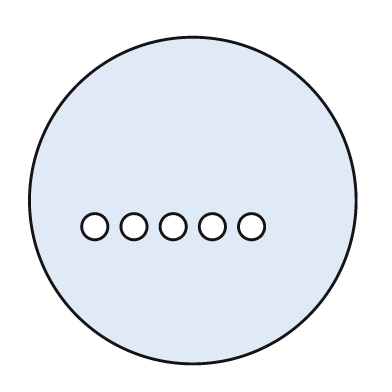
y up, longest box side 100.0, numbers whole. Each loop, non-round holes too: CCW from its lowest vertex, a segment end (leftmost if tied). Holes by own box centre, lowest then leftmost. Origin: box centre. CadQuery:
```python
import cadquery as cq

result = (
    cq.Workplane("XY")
    .moveTo(0.0, 0.0)
    .circle(50.0)
    .moveTo(-30.0, -8.0)
    .circle(4.0)
    .moveTo(-18.0, -8.0)
    .circle(4.0)
    .moveTo(-6.0, -8.0)
    .circle(4.0)
    .moveTo(6.0, -8.0)
    .circle(4.0)
    .moveTo(18.0, -8.0)
    .circle(4.0)
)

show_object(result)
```